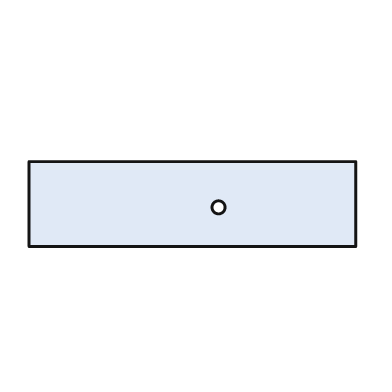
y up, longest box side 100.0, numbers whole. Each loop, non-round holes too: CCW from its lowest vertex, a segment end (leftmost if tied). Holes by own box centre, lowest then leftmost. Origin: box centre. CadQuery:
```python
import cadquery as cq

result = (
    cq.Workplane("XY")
    .moveTo(-50.0, -13.0)
    .lineTo(50.0, -13.0)
    .lineTo(50.0, 13.0)
    .lineTo(-50.0, 13.0)
    .close()
    .moveTo(8.0, -1.0)
    .circle(2.0)
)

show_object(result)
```